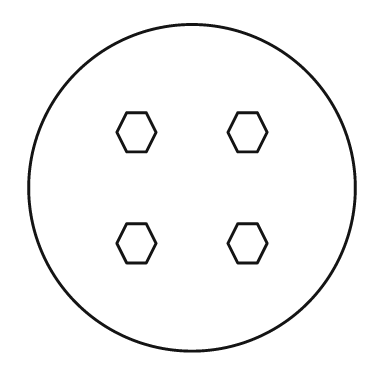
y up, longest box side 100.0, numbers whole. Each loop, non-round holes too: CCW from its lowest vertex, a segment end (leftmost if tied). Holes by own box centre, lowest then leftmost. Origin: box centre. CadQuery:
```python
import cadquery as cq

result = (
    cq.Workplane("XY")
    .moveTo(0.0, 0.0)
    .circle(50.0)
    .moveTo(-20.0, -23.0)
    .lineTo(-14.0, -23.0)
    .lineTo(-11.0, -17.0)
    .lineTo(-14.0, -11.0)
    .lineTo(-20.0, -11.0)
    .lineTo(-23.0, -17.0)
    .close()
    .moveTo(14.0, -23.0)
    .lineTo(20.0, -23.0)
    .lineTo(23.0, -17.0)
    .lineTo(20.0, -11.0)
    .lineTo(14.0, -11.0)
    .lineTo(11.0, -17.0)
    .close()
    .moveTo(-20.0, 11.0)
    .lineTo(-14.0, 11.0)
    .lineTo(-11.0, 17.0)
    .lineTo(-14.0, 23.0)
    .lineTo(-20.0, 23.0)
    .lineTo(-23.0, 17.0)
    .close()
    .moveTo(14.0, 11.0)
    .lineTo(20.0, 11.0)
    .lineTo(23.0, 17.0)
    .lineTo(20.0, 23.0)
    .lineTo(14.0, 23.0)
    .lineTo(11.0, 17.0)
    .close()
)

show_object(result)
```